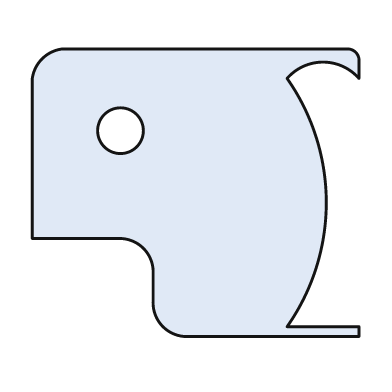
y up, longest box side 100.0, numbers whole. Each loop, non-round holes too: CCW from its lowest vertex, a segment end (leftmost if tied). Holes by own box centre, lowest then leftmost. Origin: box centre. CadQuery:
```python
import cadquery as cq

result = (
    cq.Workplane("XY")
    .moveTo(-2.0, -44.0)
    .lineTo(50.0, -44.0)
    .lineTo(50.0, -41.0)
    .lineTo(28.0, -41.0)
    .threePointArc((40.0, -3.0), (28.0, 35.0))
    .threePointArc((39.0, 40.0), (50.0, 35.0))
    .lineTo(50.0, 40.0)
    .threePointArc((49.0, 43.0), (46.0, 44.0))
    .lineTo(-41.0, 44.0)
    .threePointArc((-47.0, 41.0), (-50.0, 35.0))
    .lineTo(-50.0, -14.0)
    .lineTo(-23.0, -14.0)
    .threePointArc((-16.0, -17.0), (-13.0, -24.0))
    .lineTo(-13.0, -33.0)
    .threePointArc((-10.0, -41.0), (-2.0, -44.0))
    .close()
    .moveTo(-23.0, 19.0)
    .circle(7.0)
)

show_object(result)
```